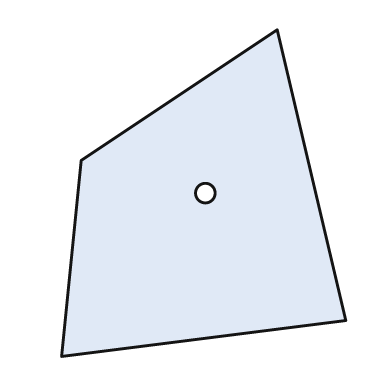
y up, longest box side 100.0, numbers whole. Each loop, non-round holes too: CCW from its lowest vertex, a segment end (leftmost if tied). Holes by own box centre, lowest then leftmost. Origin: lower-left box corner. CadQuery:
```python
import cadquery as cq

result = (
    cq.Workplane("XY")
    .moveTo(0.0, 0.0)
    .lineTo(87.0, 11.0)
    .lineTo(66.0, 100.0)
    .lineTo(6.0, 60.0)
    .close()
    .moveTo(44.0, 50.0)
    .circle(3.0)
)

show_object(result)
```